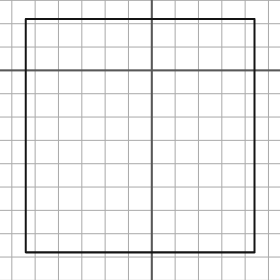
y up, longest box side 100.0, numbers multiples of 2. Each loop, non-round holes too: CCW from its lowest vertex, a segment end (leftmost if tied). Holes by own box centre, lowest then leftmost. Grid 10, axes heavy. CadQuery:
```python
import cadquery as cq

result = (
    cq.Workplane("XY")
    .moveTo(-54.0, -78.0)
    .lineTo(44.0, -78.0)
    .lineTo(44.0, 22.0)
    .lineTo(-54.0, 22.0)
    .close()
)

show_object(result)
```